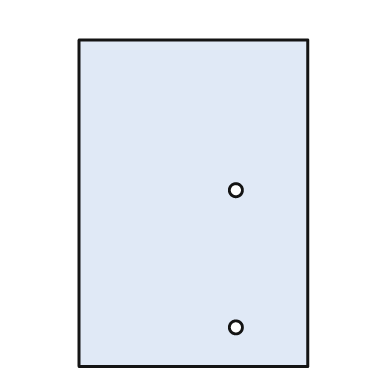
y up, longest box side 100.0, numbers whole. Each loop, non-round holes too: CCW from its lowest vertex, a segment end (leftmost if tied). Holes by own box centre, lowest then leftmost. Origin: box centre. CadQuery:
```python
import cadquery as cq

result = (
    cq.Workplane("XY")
    .moveTo(-35.0, -50.0)
    .lineTo(35.0, -50.0)
    .lineTo(35.0, 50.0)
    .lineTo(-35.0, 50.0)
    .close()
    .moveTo(13.0, -38.0)
    .circle(2.0)
    .moveTo(13.0, 4.0)
    .circle(2.0)
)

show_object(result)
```